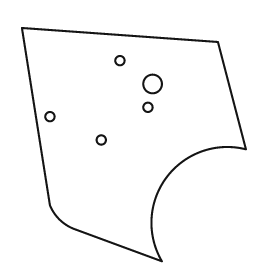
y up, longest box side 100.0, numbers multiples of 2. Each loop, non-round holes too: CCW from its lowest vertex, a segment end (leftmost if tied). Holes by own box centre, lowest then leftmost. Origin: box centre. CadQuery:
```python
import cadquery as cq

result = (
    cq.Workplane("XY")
    .moveTo(12.0, -50.0)
    .threePointArc((14.0, -14.0), (48.0, -2.0))
    .lineTo(36.0, 44.0)
    .lineTo(-48.0, 50.0)
    .lineTo(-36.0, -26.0)
    .threePointArc((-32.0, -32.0), (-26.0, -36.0))
    .close()
    .moveTo(-14.0, 2.0)
    .circle(2.0)
    .moveTo(-36.0, 12.0)
    .circle(2.0)
    .moveTo(6.0, 16.0)
    .circle(2.0)
    .moveTo(8.0, 26.0)
    .circle(4.0)
    .moveTo(-6.0, 36.0)
    .circle(2.0)
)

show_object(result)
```